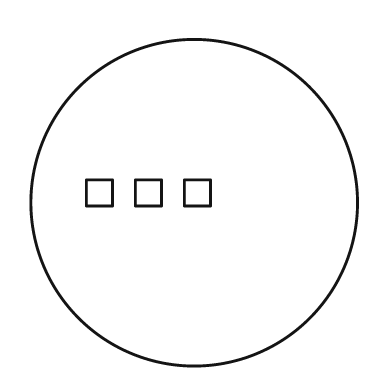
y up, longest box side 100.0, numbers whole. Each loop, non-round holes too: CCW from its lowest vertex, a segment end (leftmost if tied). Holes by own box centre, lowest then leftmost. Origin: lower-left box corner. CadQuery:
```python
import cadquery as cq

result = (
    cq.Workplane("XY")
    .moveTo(50.0, 50.0)
    .circle(50.0)
    .moveTo(17.0, 49.0)
    .lineTo(25.0, 49.0)
    .lineTo(25.0, 57.0)
    .lineTo(17.0, 57.0)
    .close()
    .moveTo(32.0, 49.0)
    .lineTo(40.0, 49.0)
    .lineTo(40.0, 57.0)
    .lineTo(32.0, 57.0)
    .close()
    .moveTo(47.0, 49.0)
    .lineTo(55.0, 49.0)
    .lineTo(55.0, 57.0)
    .lineTo(47.0, 57.0)
    .close()
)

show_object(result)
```